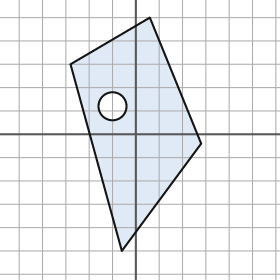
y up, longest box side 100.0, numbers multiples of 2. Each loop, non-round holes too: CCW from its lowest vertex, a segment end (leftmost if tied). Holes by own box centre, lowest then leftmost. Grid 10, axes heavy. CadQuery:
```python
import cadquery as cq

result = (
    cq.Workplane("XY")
    .moveTo(-6.0, -50.0)
    .lineTo(28.0, -4.0)
    .lineTo(6.0, 50.0)
    .lineTo(-28.0, 30.0)
    .close()
    .moveTo(-10.0, 12.0)
    .circle(6.0)
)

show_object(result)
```